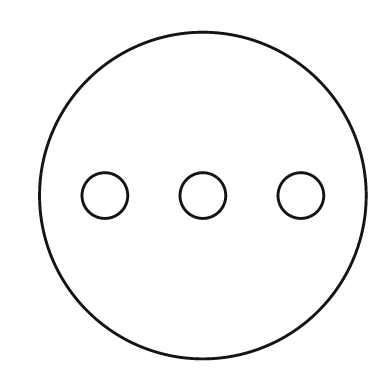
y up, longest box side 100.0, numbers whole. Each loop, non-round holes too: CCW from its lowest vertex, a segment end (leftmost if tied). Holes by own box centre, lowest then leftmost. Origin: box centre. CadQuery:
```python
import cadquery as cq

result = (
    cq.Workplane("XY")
    .moveTo(0.0, 0.0)
    .circle(50.0)
    .moveTo(-30.0, 0.0)
    .circle(7.0)
    .moveTo(0.0, 0.0)
    .circle(7.0)
    .moveTo(30.0, 0.0)
    .circle(7.0)
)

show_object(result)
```